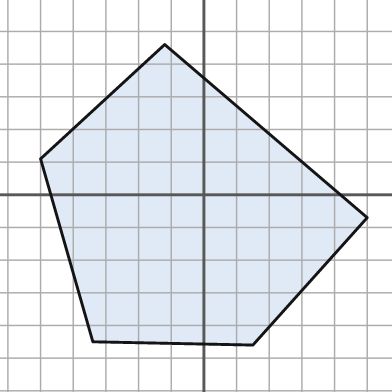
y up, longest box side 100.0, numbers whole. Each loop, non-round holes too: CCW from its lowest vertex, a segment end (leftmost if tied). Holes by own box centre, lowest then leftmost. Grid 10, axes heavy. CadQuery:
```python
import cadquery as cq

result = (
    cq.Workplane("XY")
    .moveTo(15.0, -46.0)
    .lineTo(50.0, -7.0)
    .lineTo(-12.0, 46.0)
    .lineTo(-50.0, 11.0)
    .lineTo(-34.0, -45.0)
    .close()
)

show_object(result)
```